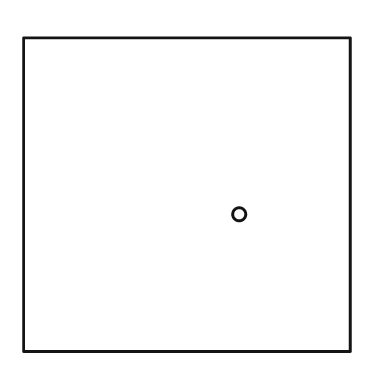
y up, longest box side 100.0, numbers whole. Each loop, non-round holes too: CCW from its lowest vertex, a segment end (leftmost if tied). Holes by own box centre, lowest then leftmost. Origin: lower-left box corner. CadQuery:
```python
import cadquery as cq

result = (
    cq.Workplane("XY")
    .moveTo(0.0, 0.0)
    .lineTo(100.0, 0.0)
    .lineTo(100.0, 96.0)
    .lineTo(0.0, 96.0)
    .close()
    .moveTo(66.0, 42.0)
    .circle(2.0)
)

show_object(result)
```